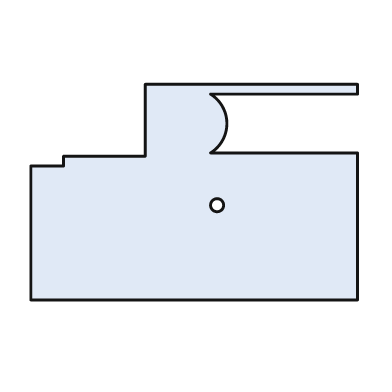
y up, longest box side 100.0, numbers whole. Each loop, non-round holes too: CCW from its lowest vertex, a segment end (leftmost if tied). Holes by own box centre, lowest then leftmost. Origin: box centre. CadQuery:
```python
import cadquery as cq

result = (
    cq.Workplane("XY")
    .moveTo(-50.0, -33.0)
    .lineTo(50.0, -33.0)
    .lineTo(50.0, 12.0)
    .lineTo(5.0, 12.0)
    .threePointArc((10.0, 21.0), (5.0, 30.0))
    .lineTo(50.0, 30.0)
    .lineTo(50.0, 33.0)
    .lineTo(-15.0, 33.0)
    .lineTo(-15.0, 11.0)
    .lineTo(-40.0, 11.0)
    .lineTo(-40.0, 8.0)
    .lineTo(-50.0, 8.0)
    .close()
    .moveTo(7.0, -4.0)
    .circle(2.0)
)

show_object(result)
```